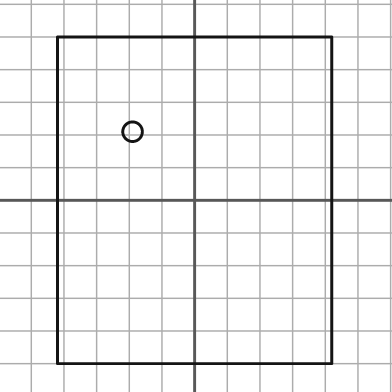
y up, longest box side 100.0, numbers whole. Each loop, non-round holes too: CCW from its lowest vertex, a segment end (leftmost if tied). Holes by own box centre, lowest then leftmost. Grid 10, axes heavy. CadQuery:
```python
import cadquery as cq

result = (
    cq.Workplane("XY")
    .moveTo(-42.0, -50.0)
    .lineTo(42.0, -50.0)
    .lineTo(42.0, 50.0)
    .lineTo(-42.0, 50.0)
    .close()
    .moveTo(-19.0, 21.0)
    .circle(3.0)
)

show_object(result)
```